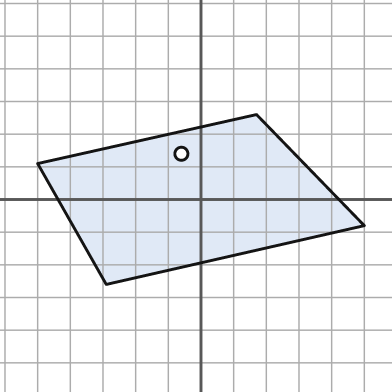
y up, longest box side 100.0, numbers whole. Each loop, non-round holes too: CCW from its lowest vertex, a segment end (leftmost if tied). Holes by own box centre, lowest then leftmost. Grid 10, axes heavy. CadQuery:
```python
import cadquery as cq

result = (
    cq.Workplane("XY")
    .moveTo(-29.0, -26.0)
    .lineTo(50.0, -8.0)
    .lineTo(17.0, 26.0)
    .lineTo(-50.0, 11.0)
    .close()
    .moveTo(-6.0, 14.0)
    .circle(2.0)
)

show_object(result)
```